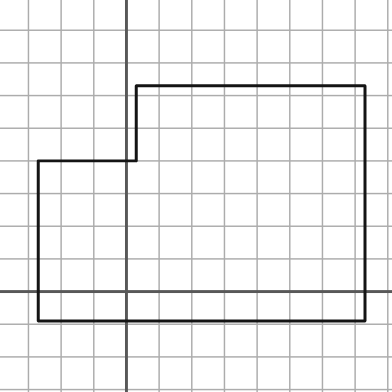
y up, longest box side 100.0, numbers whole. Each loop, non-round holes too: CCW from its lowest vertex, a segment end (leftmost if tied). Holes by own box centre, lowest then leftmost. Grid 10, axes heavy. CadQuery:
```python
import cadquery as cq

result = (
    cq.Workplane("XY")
    .moveTo(-27.0, -9.0)
    .lineTo(73.0, -9.0)
    .lineTo(73.0, 63.0)
    .lineTo(3.0, 63.0)
    .lineTo(3.0, 40.0)
    .lineTo(-27.0, 40.0)
    .close()
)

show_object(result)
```